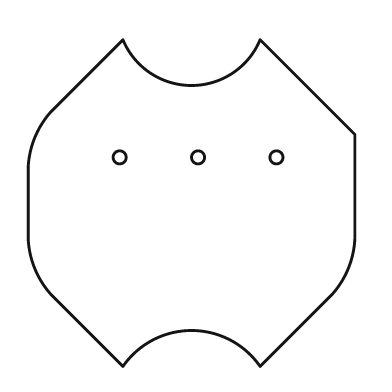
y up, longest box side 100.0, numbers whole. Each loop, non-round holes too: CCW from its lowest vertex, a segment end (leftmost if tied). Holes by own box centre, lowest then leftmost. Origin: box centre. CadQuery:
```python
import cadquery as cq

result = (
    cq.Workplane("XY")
    .moveTo(-21.0, -50.0)
    .threePointArc((0.0, -39.0), (21.0, -50.0))
    .lineTo(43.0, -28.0)
    .threePointArc((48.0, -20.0), (50.0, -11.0))
    .lineTo(50.0, 21.0)
    .lineTo(21.0, 50.0)
    .threePointArc((0.0, 36.0), (-21.0, 50.0))
    .lineTo(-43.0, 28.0)
    .threePointArc((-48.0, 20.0), (-50.0, 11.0))
    .lineTo(-50.0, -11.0)
    .threePointArc((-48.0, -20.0), (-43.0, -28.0))
    .close()
    .moveTo(-22.0, 14.0)
    .circle(2.0)
    .moveTo(2.0, 14.0)
    .circle(2.0)
    .moveTo(26.0, 14.0)
    .circle(2.0)
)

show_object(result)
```